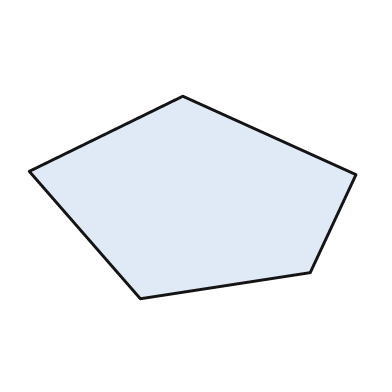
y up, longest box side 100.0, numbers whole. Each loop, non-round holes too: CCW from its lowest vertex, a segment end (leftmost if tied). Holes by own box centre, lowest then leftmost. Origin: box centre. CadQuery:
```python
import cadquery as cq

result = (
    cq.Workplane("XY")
    .moveTo(-16.0, -31.0)
    .lineTo(36.0, -23.0)
    .lineTo(50.0, 7.0)
    .lineTo(-3.0, 31.0)
    .lineTo(-50.0, 8.0)
    .close()
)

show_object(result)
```